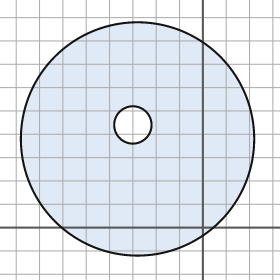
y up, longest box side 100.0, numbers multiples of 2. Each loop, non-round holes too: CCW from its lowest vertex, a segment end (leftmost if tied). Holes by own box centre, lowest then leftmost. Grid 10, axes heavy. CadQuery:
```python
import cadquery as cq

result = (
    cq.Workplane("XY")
    .moveTo(-28.0, 38.0)
    .circle(50.0)
    .moveTo(-30.0, 44.0)
    .circle(8.0)
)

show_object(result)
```